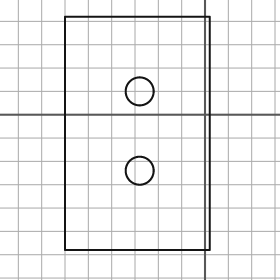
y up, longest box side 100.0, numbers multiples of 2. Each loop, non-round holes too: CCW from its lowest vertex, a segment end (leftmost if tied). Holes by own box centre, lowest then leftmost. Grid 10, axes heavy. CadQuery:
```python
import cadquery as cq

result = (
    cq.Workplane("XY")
    .moveTo(-60.0, -58.0)
    .lineTo(2.0, -58.0)
    .lineTo(2.0, 42.0)
    .lineTo(-60.0, 42.0)
    .close()
    .moveTo(-28.0, -24.0)
    .circle(6.0)
    .moveTo(-28.0, 10.0)
    .circle(6.0)
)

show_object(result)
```